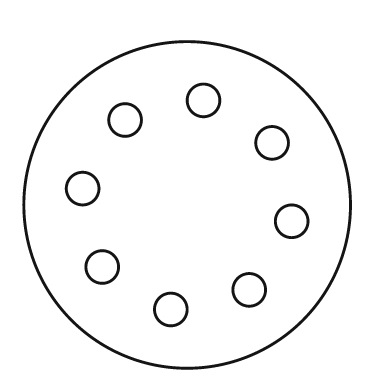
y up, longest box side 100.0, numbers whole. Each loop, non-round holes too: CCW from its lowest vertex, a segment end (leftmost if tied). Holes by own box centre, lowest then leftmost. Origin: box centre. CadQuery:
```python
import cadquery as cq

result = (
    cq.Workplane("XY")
    .moveTo(0.0, 0.0)
    .circle(50.0)
    .moveTo(-5.0, -32.0)
    .circle(5.0)
    .moveTo(19.0, -26.0)
    .circle(5.0)
    .moveTo(-26.0, -19.0)
    .circle(5.0)
    .moveTo(32.0, -5.0)
    .circle(5.0)
    .moveTo(-32.0, 5.0)
    .circle(5.0)
    .moveTo(26.0, 19.0)
    .circle(5.0)
    .moveTo(-19.0, 26.0)
    .circle(5.0)
    .moveTo(5.0, 32.0)
    .circle(5.0)
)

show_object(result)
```